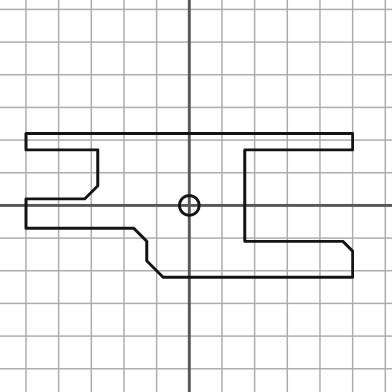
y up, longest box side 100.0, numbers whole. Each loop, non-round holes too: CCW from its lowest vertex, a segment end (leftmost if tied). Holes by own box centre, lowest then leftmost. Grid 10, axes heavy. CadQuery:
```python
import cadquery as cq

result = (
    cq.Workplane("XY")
    .moveTo(-8.0, -22.0)
    .lineTo(50.0, -22.0)
    .lineTo(50.0, -14.0)
    .lineTo(47.0, -11.0)
    .lineTo(17.0, -11.0)
    .lineTo(17.0, 17.0)
    .lineTo(50.0, 17.0)
    .lineTo(50.0, 22.0)
    .lineTo(-50.0, 22.0)
    .lineTo(-50.0, 17.0)
    .lineTo(-28.0, 17.0)
    .lineTo(-28.0, 6.0)
    .lineTo(-32.0, 2.0)
    .lineTo(-50.0, 2.0)
    .lineTo(-50.0, -7.0)
    .lineTo(-17.0, -7.0)
    .lineTo(-13.0, -11.0)
    .lineTo(-13.0, -17.0)
    .close()
    .moveTo(0.0, 0.0)
    .circle(3.0)
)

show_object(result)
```